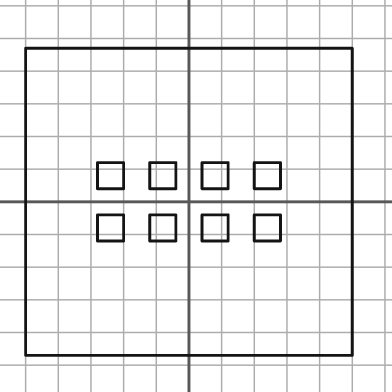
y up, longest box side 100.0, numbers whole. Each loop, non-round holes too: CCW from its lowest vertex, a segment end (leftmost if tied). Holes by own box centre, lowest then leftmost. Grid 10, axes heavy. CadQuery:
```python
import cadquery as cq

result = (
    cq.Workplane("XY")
    .moveTo(-50.0, -47.0)
    .lineTo(50.0, -47.0)
    .lineTo(50.0, 47.0)
    .lineTo(-50.0, 47.0)
    .close()
    .moveTo(-28.0, -12.0)
    .lineTo(-20.0, -12.0)
    .lineTo(-20.0, -4.0)
    .lineTo(-28.0, -4.0)
    .close()
    .moveTo(-12.0, -12.0)
    .lineTo(-4.0, -12.0)
    .lineTo(-4.0, -4.0)
    .lineTo(-12.0, -4.0)
    .close()
    .moveTo(4.0, -12.0)
    .lineTo(12.0, -12.0)
    .lineTo(12.0, -4.0)
    .lineTo(4.0, -4.0)
    .close()
    .moveTo(20.0, -12.0)
    .lineTo(28.0, -12.0)
    .lineTo(28.0, -4.0)
    .lineTo(20.0, -4.0)
    .close()
    .moveTo(-28.0, 4.0)
    .lineTo(-20.0, 4.0)
    .lineTo(-20.0, 12.0)
    .lineTo(-28.0, 12.0)
    .close()
    .moveTo(-12.0, 4.0)
    .lineTo(-4.0, 4.0)
    .lineTo(-4.0, 12.0)
    .lineTo(-12.0, 12.0)
    .close()
    .moveTo(4.0, 4.0)
    .lineTo(12.0, 4.0)
    .lineTo(12.0, 12.0)
    .lineTo(4.0, 12.0)
    .close()
    .moveTo(20.0, 4.0)
    .lineTo(28.0, 4.0)
    .lineTo(28.0, 12.0)
    .lineTo(20.0, 12.0)
    .close()
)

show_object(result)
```